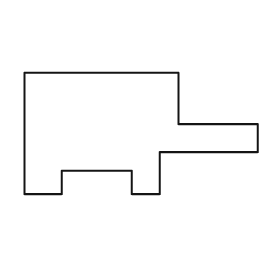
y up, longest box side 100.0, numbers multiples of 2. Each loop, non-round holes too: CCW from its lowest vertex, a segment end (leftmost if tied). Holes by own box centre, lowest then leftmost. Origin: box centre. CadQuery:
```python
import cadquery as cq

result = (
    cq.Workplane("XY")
    .moveTo(-50.0, -26.0)
    .lineTo(-34.0, -26.0)
    .lineTo(-34.0, -16.0)
    .lineTo(-4.0, -16.0)
    .lineTo(-4.0, -26.0)
    .lineTo(8.0, -26.0)
    .lineTo(8.0, -8.0)
    .lineTo(50.0, -8.0)
    .lineTo(50.0, 4.0)
    .lineTo(16.0, 4.0)
    .lineTo(16.0, 26.0)
    .lineTo(-50.0, 26.0)
    .close()
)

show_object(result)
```